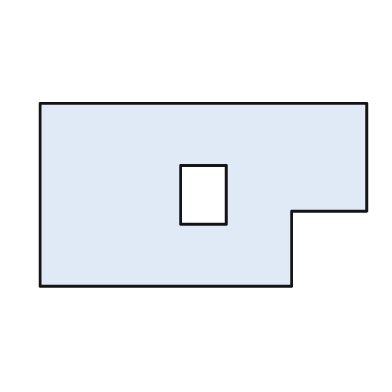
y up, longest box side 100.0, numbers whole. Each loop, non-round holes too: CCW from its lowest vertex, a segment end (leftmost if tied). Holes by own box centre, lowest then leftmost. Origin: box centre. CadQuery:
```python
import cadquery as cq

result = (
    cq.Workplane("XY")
    .moveTo(-50.0, -28.0)
    .lineTo(27.0, -28.0)
    .lineTo(27.0, -5.0)
    .lineTo(50.0, -5.0)
    .lineTo(50.0, 28.0)
    .lineTo(-50.0, 28.0)
    .close()
    .moveTo(-7.0, -9.0)
    .lineTo(7.0, -9.0)
    .lineTo(7.0, 9.0)
    .lineTo(-7.0, 9.0)
    .close()
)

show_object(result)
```